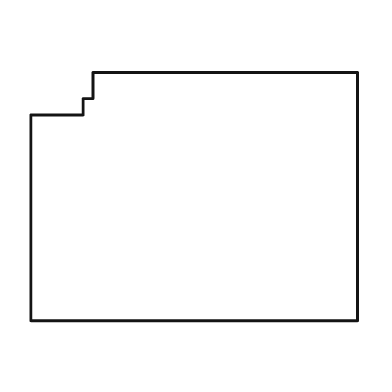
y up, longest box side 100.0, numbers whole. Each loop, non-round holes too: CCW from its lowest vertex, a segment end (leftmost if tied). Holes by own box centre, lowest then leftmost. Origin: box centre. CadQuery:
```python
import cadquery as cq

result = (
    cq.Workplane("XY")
    .moveTo(-50.0, -38.0)
    .lineTo(50.0, -38.0)
    .lineTo(50.0, 38.0)
    .lineTo(-31.0, 38.0)
    .lineTo(-31.0, 30.0)
    .lineTo(-34.0, 30.0)
    .lineTo(-34.0, 25.0)
    .lineTo(-50.0, 25.0)
    .close()
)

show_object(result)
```